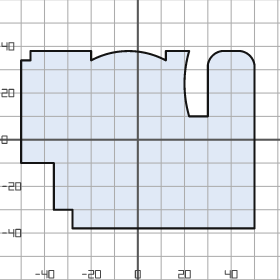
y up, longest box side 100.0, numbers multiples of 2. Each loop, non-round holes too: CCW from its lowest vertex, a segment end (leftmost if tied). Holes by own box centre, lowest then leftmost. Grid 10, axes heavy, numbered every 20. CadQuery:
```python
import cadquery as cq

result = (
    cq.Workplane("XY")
    .moveTo(-28.0, -38.0)
    .lineTo(50.0, -38.0)
    .lineTo(50.0, 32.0)
    .threePointArc((48.0, 36.0), (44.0, 38.0))
    .lineTo(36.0, 38.0)
    .threePointArc((32.0, 36.0), (30.0, 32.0))
    .lineTo(30.0, 10.0)
    .lineTo(22.0, 10.0)
    .threePointArc((20.0, 24.0), (22.0, 38.0))
    .lineTo(12.0, 38.0)
    .lineTo(12.0, 34.0)
    .threePointArc((-4.0, 38.0), (-20.0, 34.0))
    .lineTo(-20.0, 38.0)
    .lineTo(-46.0, 38.0)
    .lineTo(-46.0, 34.0)
    .lineTo(-50.0, 34.0)
    .lineTo(-50.0, -10.0)
    .lineTo(-36.0, -10.0)
    .lineTo(-36.0, -30.0)
    .lineTo(-28.0, -30.0)
    .close()
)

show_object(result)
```